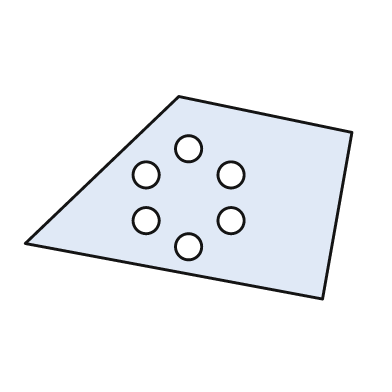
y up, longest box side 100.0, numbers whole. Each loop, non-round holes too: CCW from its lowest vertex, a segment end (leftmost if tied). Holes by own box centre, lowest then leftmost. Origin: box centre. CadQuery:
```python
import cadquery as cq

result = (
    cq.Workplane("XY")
    .moveTo(41.0, -31.0)
    .lineTo(50.0, 20.0)
    .lineTo(-3.0, 31.0)
    .lineTo(-50.0, -14.0)
    .close()
    .moveTo(0.0, -15.0)
    .circle(4.0)
    .moveTo(-13.0, -7.0)
    .circle(4.0)
    .moveTo(13.0, -7.0)
    .circle(4.0)
    .moveTo(-13.0, 7.0)
    .circle(4.0)
    .moveTo(13.0, 7.0)
    .circle(4.0)
    .moveTo(0.0, 15.0)
    .circle(4.0)
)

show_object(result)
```